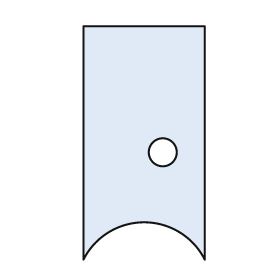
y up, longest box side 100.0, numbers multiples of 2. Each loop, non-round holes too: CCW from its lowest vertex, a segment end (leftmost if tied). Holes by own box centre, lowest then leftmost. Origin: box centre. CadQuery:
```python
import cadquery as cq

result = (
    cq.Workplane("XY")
    .moveTo(-26.0, -50.0)
    .threePointArc((0.0, -34.0), (26.0, -50.0))
    .lineTo(26.0, 50.0)
    .lineTo(-26.0, 50.0)
    .close()
    .moveTo(8.0, -4.0)
    .circle(6.0)
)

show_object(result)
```